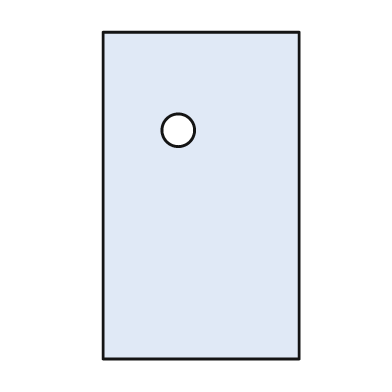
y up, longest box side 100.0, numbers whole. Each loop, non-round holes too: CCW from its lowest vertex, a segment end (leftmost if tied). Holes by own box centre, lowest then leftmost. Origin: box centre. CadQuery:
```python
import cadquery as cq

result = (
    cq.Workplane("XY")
    .moveTo(-30.0, -50.0)
    .lineTo(30.0, -50.0)
    .lineTo(30.0, 50.0)
    .lineTo(-30.0, 50.0)
    .close()
    .moveTo(-7.0, 20.0)
    .circle(5.0)
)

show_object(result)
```